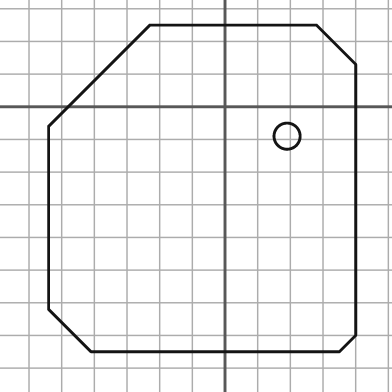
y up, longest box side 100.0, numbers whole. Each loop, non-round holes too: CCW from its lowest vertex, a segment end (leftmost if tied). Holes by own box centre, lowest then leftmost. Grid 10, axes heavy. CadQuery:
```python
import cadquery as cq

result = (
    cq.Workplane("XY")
    .moveTo(-41.0, -75.0)
    .lineTo(35.0, -75.0)
    .lineTo(40.0, -70.0)
    .lineTo(40.0, 13.0)
    .lineTo(28.0, 25.0)
    .lineTo(-23.0, 25.0)
    .lineTo(-54.0, -6.0)
    .lineTo(-54.0, -62.0)
    .close()
    .moveTo(19.0, -9.0)
    .circle(4.0)
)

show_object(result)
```